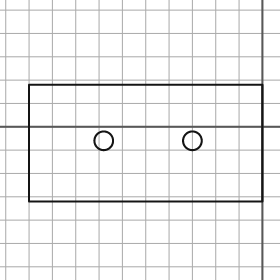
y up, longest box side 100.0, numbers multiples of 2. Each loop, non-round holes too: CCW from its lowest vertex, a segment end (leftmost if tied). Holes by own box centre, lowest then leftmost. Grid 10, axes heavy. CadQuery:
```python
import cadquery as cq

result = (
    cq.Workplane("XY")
    .moveTo(-100.0, -32.0)
    .lineTo(0.0, -32.0)
    .lineTo(0.0, 18.0)
    .lineTo(-100.0, 18.0)
    .close()
    .moveTo(-68.0, -6.0)
    .circle(4.0)
    .moveTo(-30.0, -6.0)
    .circle(4.0)
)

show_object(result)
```